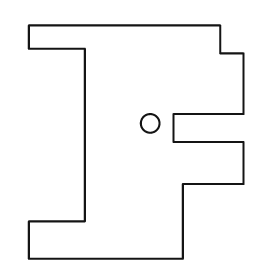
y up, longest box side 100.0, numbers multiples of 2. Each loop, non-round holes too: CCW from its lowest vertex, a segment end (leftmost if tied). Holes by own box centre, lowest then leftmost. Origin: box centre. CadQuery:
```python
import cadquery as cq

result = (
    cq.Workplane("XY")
    .moveTo(-46.0, -50.0)
    .lineTo(20.0, -50.0)
    .lineTo(20.0, -18.0)
    .lineTo(46.0, -18.0)
    .lineTo(46.0, 0.0)
    .lineTo(16.0, 0.0)
    .lineTo(16.0, 12.0)
    .lineTo(46.0, 12.0)
    .lineTo(46.0, 38.0)
    .lineTo(36.0, 38.0)
    .lineTo(36.0, 50.0)
    .lineTo(-46.0, 50.0)
    .lineTo(-46.0, 40.0)
    .lineTo(-22.0, 40.0)
    .lineTo(-22.0, -34.0)
    .lineTo(-46.0, -34.0)
    .close()
    .moveTo(6.0, 8.0)
    .circle(4.0)
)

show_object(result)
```